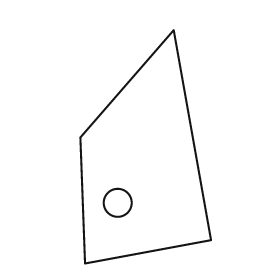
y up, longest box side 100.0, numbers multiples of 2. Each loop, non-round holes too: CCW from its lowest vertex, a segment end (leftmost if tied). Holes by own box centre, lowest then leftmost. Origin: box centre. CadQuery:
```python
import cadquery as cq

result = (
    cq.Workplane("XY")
    .moveTo(-26.0, -50.0)
    .lineTo(28.0, -40.0)
    .lineTo(12.0, 50.0)
    .lineTo(-28.0, 4.0)
    .close()
    .moveTo(-12.0, -24.0)
    .circle(6.0)
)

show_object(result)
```